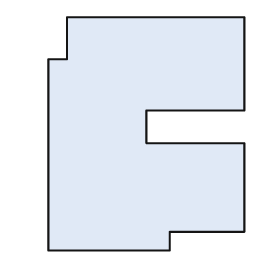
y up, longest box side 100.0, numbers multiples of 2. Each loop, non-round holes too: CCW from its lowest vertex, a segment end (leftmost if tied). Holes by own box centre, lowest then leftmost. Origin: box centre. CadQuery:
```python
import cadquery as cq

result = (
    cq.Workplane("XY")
    .moveTo(-42.0, -50.0)
    .lineTo(10.0, -50.0)
    .lineTo(10.0, -42.0)
    .lineTo(42.0, -42.0)
    .lineTo(42.0, -4.0)
    .lineTo(0.0, -4.0)
    .lineTo(0.0, 10.0)
    .lineTo(42.0, 10.0)
    .lineTo(42.0, 50.0)
    .lineTo(-34.0, 50.0)
    .lineTo(-34.0, 32.0)
    .lineTo(-42.0, 32.0)
    .close()
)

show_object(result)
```